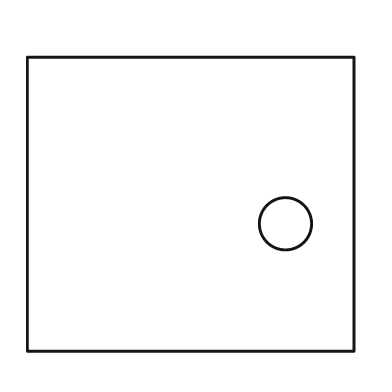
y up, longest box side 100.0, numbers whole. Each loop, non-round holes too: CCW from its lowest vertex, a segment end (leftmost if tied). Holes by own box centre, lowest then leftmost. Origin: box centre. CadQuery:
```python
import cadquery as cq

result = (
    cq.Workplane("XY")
    .moveTo(-50.0, -45.0)
    .lineTo(50.0, -45.0)
    .lineTo(50.0, 45.0)
    .lineTo(-50.0, 45.0)
    .close()
    .moveTo(29.0, -6.0)
    .circle(8.0)
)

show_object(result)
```